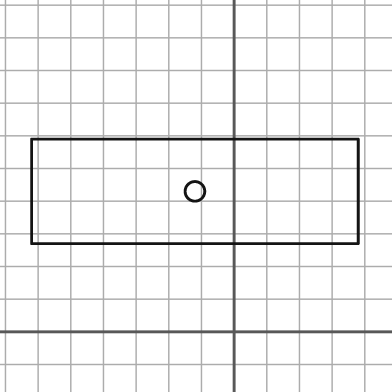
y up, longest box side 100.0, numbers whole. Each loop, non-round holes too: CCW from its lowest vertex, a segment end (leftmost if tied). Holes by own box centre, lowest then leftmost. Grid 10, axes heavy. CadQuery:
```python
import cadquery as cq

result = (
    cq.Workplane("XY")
    .moveTo(-62.0, 27.0)
    .lineTo(38.0, 27.0)
    .lineTo(38.0, 59.0)
    .lineTo(-62.0, 59.0)
    .close()
    .moveTo(-12.0, 43.0)
    .circle(3.0)
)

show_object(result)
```